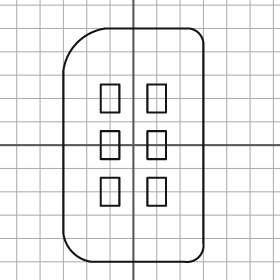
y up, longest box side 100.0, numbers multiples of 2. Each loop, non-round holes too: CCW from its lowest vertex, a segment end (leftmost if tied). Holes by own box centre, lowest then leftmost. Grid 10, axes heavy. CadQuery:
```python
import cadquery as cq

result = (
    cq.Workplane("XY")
    .moveTo(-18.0, -50.0)
    .lineTo(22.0, -50.0)
    .threePointArc((28.0, -48.0), (30.0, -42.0))
    .lineTo(30.0, 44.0)
    .threePointArc((28.0, 48.0), (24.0, 50.0))
    .lineTo(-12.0, 50.0)
    .threePointArc((-24.0, 44.0), (-30.0, 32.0))
    .lineTo(-30.0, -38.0)
    .threePointArc((-26.0, -46.0), (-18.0, -50.0))
    .close()
    .moveTo(-14.0, -26.0)
    .lineTo(-6.0, -26.0)
    .lineTo(-6.0, -14.0)
    .lineTo(-14.0, -14.0)
    .close()
    .moveTo(6.0, -26.0)
    .lineTo(14.0, -26.0)
    .lineTo(14.0, -14.0)
    .lineTo(6.0, -14.0)
    .close()
    .moveTo(-14.0, -6.0)
    .lineTo(-6.0, -6.0)
    .lineTo(-6.0, 6.0)
    .lineTo(-14.0, 6.0)
    .close()
    .moveTo(6.0, -6.0)
    .lineTo(14.0, -6.0)
    .lineTo(14.0, 6.0)
    .lineTo(6.0, 6.0)
    .close()
    .moveTo(-14.0, 14.0)
    .lineTo(-6.0, 14.0)
    .lineTo(-6.0, 26.0)
    .lineTo(-14.0, 26.0)
    .close()
    .moveTo(6.0, 14.0)
    .lineTo(14.0, 14.0)
    .lineTo(14.0, 26.0)
    .lineTo(6.0, 26.0)
    .close()
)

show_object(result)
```